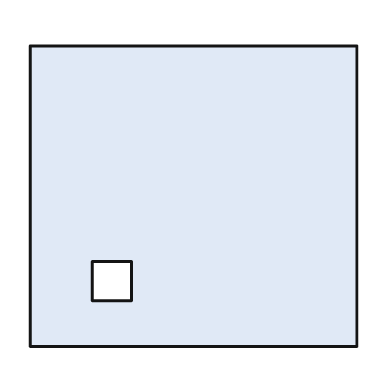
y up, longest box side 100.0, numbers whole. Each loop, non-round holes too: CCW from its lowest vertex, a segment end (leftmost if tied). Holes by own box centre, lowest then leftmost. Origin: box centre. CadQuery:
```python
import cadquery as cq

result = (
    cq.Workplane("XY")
    .moveTo(-50.0, -46.0)
    .lineTo(50.0, -46.0)
    .lineTo(50.0, 46.0)
    .lineTo(-50.0, 46.0)
    .close()
    .moveTo(-31.0, -32.0)
    .lineTo(-19.0, -32.0)
    .lineTo(-19.0, -20.0)
    .lineTo(-31.0, -20.0)
    .close()
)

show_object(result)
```